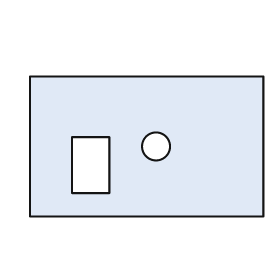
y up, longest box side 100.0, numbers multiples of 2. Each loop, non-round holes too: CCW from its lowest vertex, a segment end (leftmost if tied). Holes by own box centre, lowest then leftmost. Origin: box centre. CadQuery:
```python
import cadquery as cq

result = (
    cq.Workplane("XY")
    .moveTo(-50.0, -30.0)
    .lineTo(50.0, -30.0)
    .lineTo(50.0, 30.0)
    .lineTo(-50.0, 30.0)
    .close()
    .moveTo(-32.0, -20.0)
    .lineTo(-16.0, -20.0)
    .lineTo(-16.0, 4.0)
    .lineTo(-32.0, 4.0)
    .close()
    .moveTo(4.0, 0.0)
    .circle(6.0)
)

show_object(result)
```